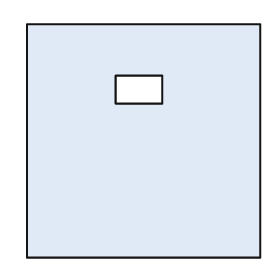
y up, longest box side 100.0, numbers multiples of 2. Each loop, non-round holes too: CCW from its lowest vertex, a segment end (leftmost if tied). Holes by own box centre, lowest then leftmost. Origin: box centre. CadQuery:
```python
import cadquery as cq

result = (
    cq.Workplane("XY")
    .moveTo(-50.0, -50.0)
    .lineTo(50.0, -50.0)
    .lineTo(50.0, 50.0)
    .lineTo(-50.0, 50.0)
    .close()
    .moveTo(-12.0, 16.0)
    .lineTo(8.0, 16.0)
    .lineTo(8.0, 28.0)
    .lineTo(-12.0, 28.0)
    .close()
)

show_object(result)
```